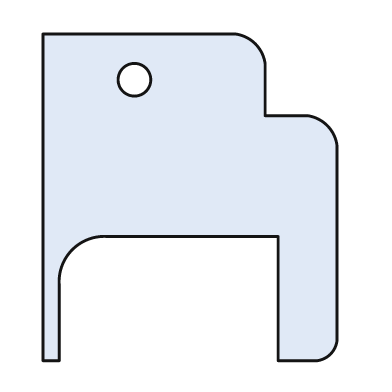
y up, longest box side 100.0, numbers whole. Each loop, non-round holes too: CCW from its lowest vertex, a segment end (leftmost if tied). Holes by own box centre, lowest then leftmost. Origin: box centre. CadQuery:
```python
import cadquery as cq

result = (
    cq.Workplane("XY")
    .moveTo(-45.0, -50.0)
    .lineTo(-40.0, -50.0)
    .lineTo(-40.0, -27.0)
    .threePointArc((-36.0, -16.0), (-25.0, -12.0))
    .lineTo(27.0, -12.0)
    .lineTo(27.0, -50.0)
    .lineTo(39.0, -50.0)
    .threePointArc((43.0, -48.0), (45.0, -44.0))
    .lineTo(45.0, 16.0)
    .threePointArc((42.0, 22.0), (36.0, 25.0))
    .lineTo(23.0, 25.0)
    .lineTo(23.0, 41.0)
    .threePointArc((20.0, 47.0), (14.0, 50.0))
    .lineTo(-45.0, 50.0)
    .close()
    .moveTo(-17.0, 36.0)
    .circle(5.0)
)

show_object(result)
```